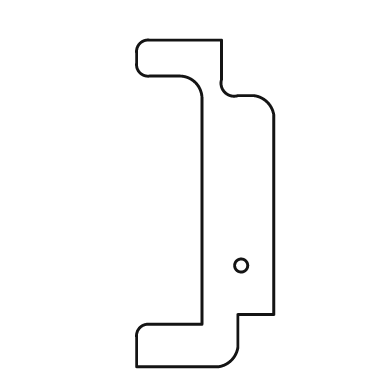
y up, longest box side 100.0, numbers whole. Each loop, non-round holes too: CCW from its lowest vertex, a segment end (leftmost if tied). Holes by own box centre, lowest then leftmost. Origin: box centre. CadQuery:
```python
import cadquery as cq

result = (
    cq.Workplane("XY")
    .moveTo(-21.0, -50.0)
    .lineTo(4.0, -50.0)
    .threePointArc((8.0, -48.0), (10.0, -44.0))
    .lineTo(10.0, -34.0)
    .lineTo(21.0, -34.0)
    .lineTo(21.0, 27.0)
    .threePointArc((19.0, 31.0), (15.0, 33.0))
    .lineTo(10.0, 33.0)
    .threePointArc((6.0, 34.0), (5.0, 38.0))
    .lineTo(5.0, 50.0)
    .lineTo(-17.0, 50.0)
    .threePointArc((-20.0, 49.0), (-21.0, 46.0))
    .lineTo(-21.0, 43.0)
    .threePointArc((-20.0, 40.0), (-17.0, 39.0))
    .lineTo(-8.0, 39.0)
    .threePointArc((-3.0, 37.0), (-1.0, 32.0))
    .lineTo(-1.0, -37.0)
    .lineTo(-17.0, -37.0)
    .threePointArc((-20.0, -38.0), (-21.0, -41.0))
    .close()
    .moveTo(11.0, -19.0)
    .circle(2.0)
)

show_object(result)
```